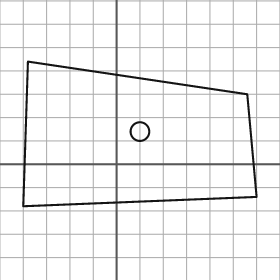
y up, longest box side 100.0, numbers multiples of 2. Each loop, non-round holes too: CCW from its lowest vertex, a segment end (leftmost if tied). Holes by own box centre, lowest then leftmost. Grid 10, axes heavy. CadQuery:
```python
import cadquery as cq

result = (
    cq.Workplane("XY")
    .moveTo(-40.0, -18.0)
    .lineTo(60.0, -14.0)
    .lineTo(56.0, 30.0)
    .lineTo(-38.0, 44.0)
    .close()
    .moveTo(10.0, 14.0)
    .circle(4.0)
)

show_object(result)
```